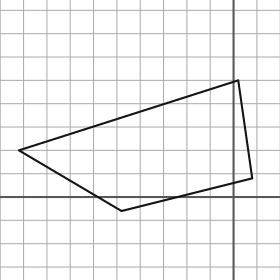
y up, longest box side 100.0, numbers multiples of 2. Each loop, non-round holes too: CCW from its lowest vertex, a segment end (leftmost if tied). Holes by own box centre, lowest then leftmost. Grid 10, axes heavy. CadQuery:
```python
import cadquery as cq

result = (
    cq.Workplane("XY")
    .moveTo(-48.0, -6.0)
    .lineTo(8.0, 8.0)
    .lineTo(2.0, 50.0)
    .lineTo(-92.0, 20.0)
    .close()
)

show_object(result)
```